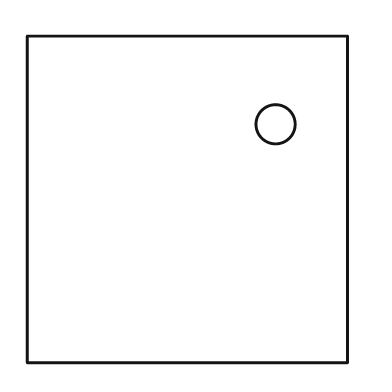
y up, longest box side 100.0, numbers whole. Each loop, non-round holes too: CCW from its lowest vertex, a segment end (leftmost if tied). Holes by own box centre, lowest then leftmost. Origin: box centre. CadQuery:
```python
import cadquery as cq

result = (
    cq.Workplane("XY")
    .moveTo(-49.0, -50.0)
    .lineTo(49.0, -50.0)
    .lineTo(49.0, 50.0)
    .lineTo(-49.0, 50.0)
    .close()
    .moveTo(27.0, 23.0)
    .circle(6.0)
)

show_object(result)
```